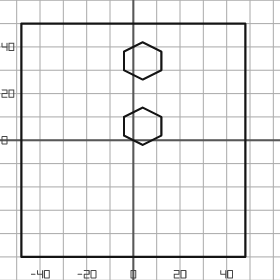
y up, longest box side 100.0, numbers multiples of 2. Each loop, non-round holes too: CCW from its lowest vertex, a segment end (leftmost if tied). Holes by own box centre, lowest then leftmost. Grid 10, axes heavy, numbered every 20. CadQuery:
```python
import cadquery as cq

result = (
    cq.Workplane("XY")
    .moveTo(-48.0, -50.0)
    .lineTo(48.0, -50.0)
    .lineTo(48.0, 50.0)
    .lineTo(-48.0, 50.0)
    .close()
    .moveTo(4.0, -2.0)
    .lineTo(12.0, 2.0)
    .lineTo(12.0, 10.0)
    .lineTo(4.0, 14.0)
    .lineTo(-4.0, 10.0)
    .lineTo(-4.0, 2.0)
    .close()
    .moveTo(4.0, 26.0)
    .lineTo(12.0, 30.0)
    .lineTo(12.0, 38.0)
    .lineTo(4.0, 42.0)
    .lineTo(-4.0, 38.0)
    .lineTo(-4.0, 30.0)
    .close()
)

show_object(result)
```